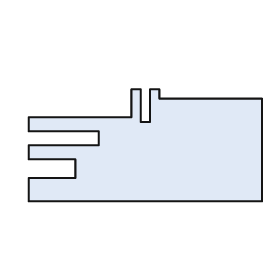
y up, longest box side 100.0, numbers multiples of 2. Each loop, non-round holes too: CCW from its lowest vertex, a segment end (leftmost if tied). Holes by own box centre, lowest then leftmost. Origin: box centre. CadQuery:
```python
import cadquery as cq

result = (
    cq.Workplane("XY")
    .moveTo(-50.0, -24.0)
    .lineTo(50.0, -24.0)
    .lineTo(50.0, 20.0)
    .lineTo(6.0, 20.0)
    .lineTo(6.0, 24.0)
    .lineTo(2.0, 24.0)
    .lineTo(2.0, 10.0)
    .lineTo(-2.0, 10.0)
    .lineTo(-2.0, 24.0)
    .lineTo(-6.0, 24.0)
    .lineTo(-6.0, 12.0)
    .lineTo(-50.0, 12.0)
    .lineTo(-50.0, 6.0)
    .lineTo(-20.0, 6.0)
    .lineTo(-20.0, 0.0)
    .lineTo(-50.0, 0.0)
    .lineTo(-50.0, -6.0)
    .lineTo(-30.0, -6.0)
    .lineTo(-30.0, -14.0)
    .lineTo(-50.0, -14.0)
    .close()
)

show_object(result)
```